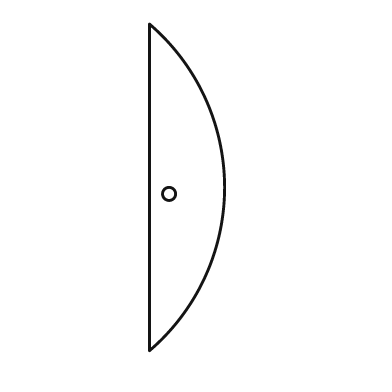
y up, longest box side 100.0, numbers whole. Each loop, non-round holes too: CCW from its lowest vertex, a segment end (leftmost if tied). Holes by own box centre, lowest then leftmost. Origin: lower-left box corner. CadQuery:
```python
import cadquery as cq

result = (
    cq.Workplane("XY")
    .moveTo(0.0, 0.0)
    .threePointArc((23.0, 50.0), (0.0, 100.0))
    .close()
    .moveTo(6.0, 48.0)
    .circle(2.0)
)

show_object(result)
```